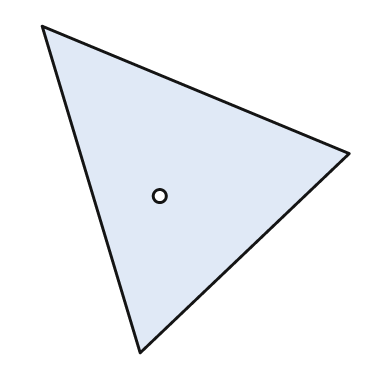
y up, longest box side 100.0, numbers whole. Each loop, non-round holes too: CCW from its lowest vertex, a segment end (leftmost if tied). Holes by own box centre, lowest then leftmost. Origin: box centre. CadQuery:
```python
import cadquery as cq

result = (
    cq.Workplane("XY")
    .moveTo(-17.0, -50.0)
    .lineTo(47.0, 11.0)
    .lineTo(-47.0, 50.0)
    .close()
    .moveTo(-11.0, -2.0)
    .circle(2.0)
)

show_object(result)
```